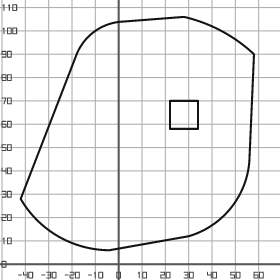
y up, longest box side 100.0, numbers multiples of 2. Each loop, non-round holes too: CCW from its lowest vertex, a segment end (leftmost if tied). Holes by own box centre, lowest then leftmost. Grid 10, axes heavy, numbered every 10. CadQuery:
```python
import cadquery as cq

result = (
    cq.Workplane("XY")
    .moveTo(-4.0, 6.0)
    .lineTo(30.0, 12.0)
    .threePointArc((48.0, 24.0), (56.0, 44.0))
    .lineTo(58.0, 90.0)
    .threePointArc((44.0, 100.0), (28.0, 106.0))
    .lineTo(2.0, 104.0)
    .threePointArc((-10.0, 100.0), (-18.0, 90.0))
    .lineTo(-42.0, 28.0)
    .threePointArc((-26.0, 12.0), (-4.0, 6.0))
    .close()
    .moveTo(22.0, 58.0)
    .lineTo(34.0, 58.0)
    .lineTo(34.0, 70.0)
    .lineTo(22.0, 70.0)
    .close()
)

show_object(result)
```